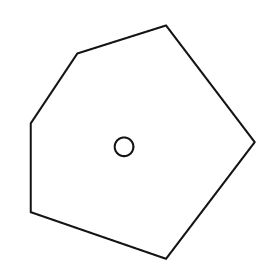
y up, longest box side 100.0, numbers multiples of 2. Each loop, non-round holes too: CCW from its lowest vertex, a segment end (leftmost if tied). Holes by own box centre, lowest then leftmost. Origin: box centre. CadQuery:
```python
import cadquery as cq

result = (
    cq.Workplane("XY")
    .moveTo(10.0, -50.0)
    .lineTo(48.0, 0.0)
    .lineTo(10.0, 50.0)
    .lineTo(-28.0, 38.0)
    .lineTo(-48.0, 8.0)
    .lineTo(-48.0, -30.0)
    .close()
    .moveTo(-8.0, -2.0)
    .circle(4.0)
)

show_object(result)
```